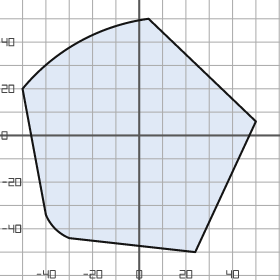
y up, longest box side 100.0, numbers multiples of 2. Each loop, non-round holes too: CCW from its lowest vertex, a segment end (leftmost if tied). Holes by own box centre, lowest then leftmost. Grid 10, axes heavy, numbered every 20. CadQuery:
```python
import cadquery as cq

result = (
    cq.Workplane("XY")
    .moveTo(24.0, -50.0)
    .lineTo(50.0, 6.0)
    .lineTo(4.0, 50.0)
    .threePointArc((-26.0, 40.0), (-50.0, 20.0))
    .lineTo(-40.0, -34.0)
    .threePointArc((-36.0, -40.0), (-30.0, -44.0))
    .close()
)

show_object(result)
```